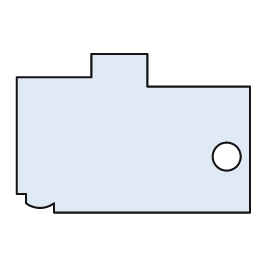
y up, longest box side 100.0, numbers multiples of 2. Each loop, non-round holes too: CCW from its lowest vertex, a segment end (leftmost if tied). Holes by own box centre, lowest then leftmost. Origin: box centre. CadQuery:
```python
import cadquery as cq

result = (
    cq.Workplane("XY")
    .moveTo(-34.0, -34.0)
    .lineTo(50.0, -34.0)
    .lineTo(50.0, 20.0)
    .lineTo(6.0, 20.0)
    .lineTo(6.0, 34.0)
    .lineTo(-18.0, 34.0)
    .lineTo(-18.0, 24.0)
    .lineTo(-50.0, 24.0)
    .lineTo(-50.0, -26.0)
    .lineTo(-46.0, -26.0)
    .lineTo(-46.0, -30.0)
    .threePointArc((-40.0, -32.0), (-34.0, -30.0))
    .close()
    .moveTo(40.0, -10.0)
    .circle(6.0)
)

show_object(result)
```